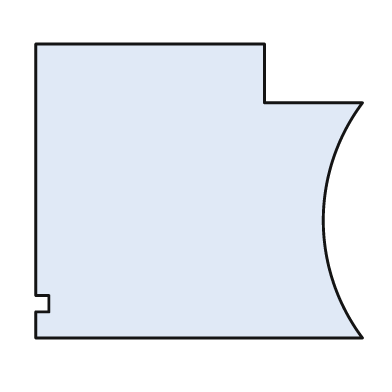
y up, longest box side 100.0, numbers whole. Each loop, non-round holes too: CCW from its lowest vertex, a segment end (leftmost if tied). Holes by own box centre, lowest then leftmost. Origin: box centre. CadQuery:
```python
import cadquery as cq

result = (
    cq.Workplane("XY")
    .moveTo(-50.0, -45.0)
    .lineTo(50.0, -45.0)
    .threePointArc((38.0, -9.0), (50.0, 27.0))
    .lineTo(20.0, 27.0)
    .lineTo(20.0, 45.0)
    .lineTo(-50.0, 45.0)
    .lineTo(-50.0, -32.0)
    .lineTo(-46.0, -32.0)
    .lineTo(-46.0, -37.0)
    .lineTo(-50.0, -37.0)
    .close()
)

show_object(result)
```